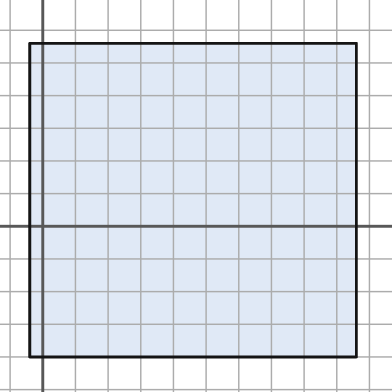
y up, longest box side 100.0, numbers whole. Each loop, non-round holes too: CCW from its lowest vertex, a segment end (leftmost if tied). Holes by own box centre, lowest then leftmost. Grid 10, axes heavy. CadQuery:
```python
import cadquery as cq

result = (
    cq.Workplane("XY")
    .moveTo(-4.0, -40.0)
    .lineTo(96.0, -40.0)
    .lineTo(96.0, 56.0)
    .lineTo(-4.0, 56.0)
    .close()
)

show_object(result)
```